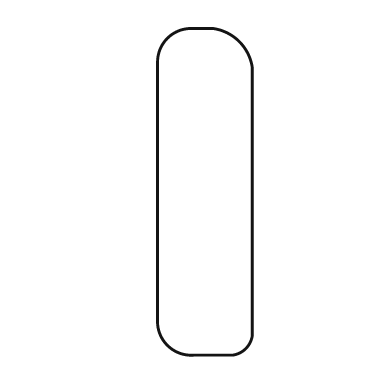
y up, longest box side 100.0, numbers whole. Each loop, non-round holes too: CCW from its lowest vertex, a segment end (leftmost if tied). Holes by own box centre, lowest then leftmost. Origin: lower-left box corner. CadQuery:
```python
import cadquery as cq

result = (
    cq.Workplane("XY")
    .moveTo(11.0, 0.0)
    .lineTo(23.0, 0.0)
    .threePointArc((27.0, 2.0), (29.0, 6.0))
    .lineTo(29.0, 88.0)
    .threePointArc((25.0, 96.0), (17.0, 100.0))
    .lineTo(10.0, 100.0)
    .threePointArc((3.0, 97.0), (0.0, 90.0))
    .lineTo(0.0, 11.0)
    .threePointArc((3.0, 3.0), (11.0, 0.0))
    .close()
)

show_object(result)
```